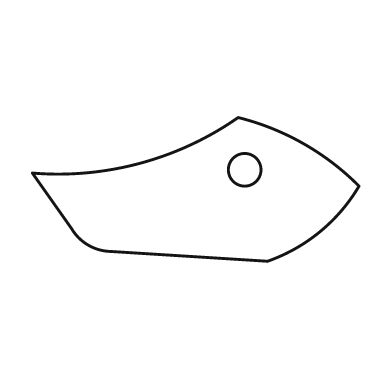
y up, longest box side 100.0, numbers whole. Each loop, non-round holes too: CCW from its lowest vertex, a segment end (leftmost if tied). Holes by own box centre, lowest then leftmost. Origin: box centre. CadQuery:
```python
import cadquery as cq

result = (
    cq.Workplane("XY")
    .moveTo(22.0, -22.0)
    .threePointArc((38.0, -13.0), (50.0, 1.0))
    .threePointArc((33.0, 14.0), (13.0, 22.0))
    .threePointArc((-17.0, 8.0), (-50.0, 5.0))
    .lineTo(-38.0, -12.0)
    .threePointArc((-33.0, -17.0), (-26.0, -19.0))
    .close()
    .moveTo(15.0, 6.0)
    .circle(5.0)
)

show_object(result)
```